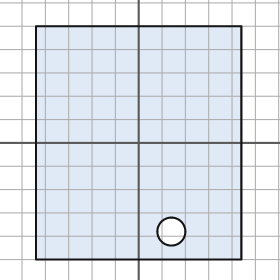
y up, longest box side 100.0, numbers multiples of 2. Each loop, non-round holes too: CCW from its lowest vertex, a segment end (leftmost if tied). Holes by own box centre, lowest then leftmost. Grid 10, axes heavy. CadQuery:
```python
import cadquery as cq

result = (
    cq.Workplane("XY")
    .moveTo(-44.0, -50.0)
    .lineTo(44.0, -50.0)
    .lineTo(44.0, 50.0)
    .lineTo(-44.0, 50.0)
    .close()
    .moveTo(14.0, -38.0)
    .circle(6.0)
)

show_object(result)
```